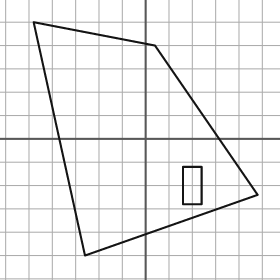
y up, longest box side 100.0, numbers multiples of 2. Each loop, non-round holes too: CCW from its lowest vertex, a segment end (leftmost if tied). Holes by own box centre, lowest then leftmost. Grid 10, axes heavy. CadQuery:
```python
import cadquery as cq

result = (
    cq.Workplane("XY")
    .moveTo(-26.0, -50.0)
    .lineTo(48.0, -24.0)
    .lineTo(4.0, 40.0)
    .lineTo(-48.0, 50.0)
    .close()
    .moveTo(16.0, -28.0)
    .lineTo(24.0, -28.0)
    .lineTo(24.0, -12.0)
    .lineTo(16.0, -12.0)
    .close()
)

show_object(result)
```